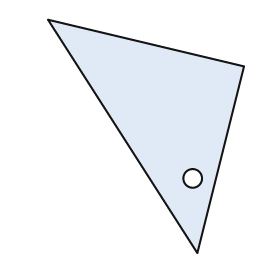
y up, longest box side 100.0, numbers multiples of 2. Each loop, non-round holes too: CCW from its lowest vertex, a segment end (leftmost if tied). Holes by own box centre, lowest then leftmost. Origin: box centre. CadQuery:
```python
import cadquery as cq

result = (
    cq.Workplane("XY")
    .moveTo(22.0, -50.0)
    .lineTo(42.0, 30.0)
    .lineTo(-42.0, 50.0)
    .close()
    .moveTo(20.0, -18.0)
    .circle(4.0)
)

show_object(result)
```